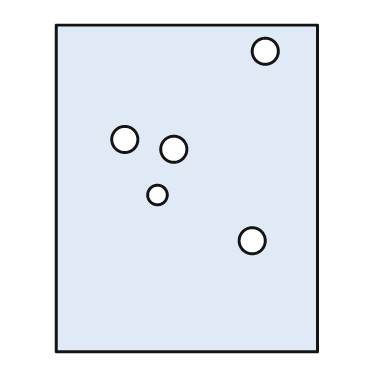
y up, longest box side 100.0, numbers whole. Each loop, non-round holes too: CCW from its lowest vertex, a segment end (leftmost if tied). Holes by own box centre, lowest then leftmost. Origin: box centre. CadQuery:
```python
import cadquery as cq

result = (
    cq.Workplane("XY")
    .moveTo(-40.0, -50.0)
    .lineTo(40.0, -50.0)
    .lineTo(40.0, 50.0)
    .lineTo(-40.0, 50.0)
    .close()
    .moveTo(20.0, -16.0)
    .circle(4.0)
    .moveTo(-9.0, -2.0)
    .circle(3.0)
    .moveTo(-4.0, 12.0)
    .circle(4.0)
    .moveTo(-19.0, 15.0)
    .circle(4.0)
    .moveTo(24.0, 42.0)
    .circle(4.0)
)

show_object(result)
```